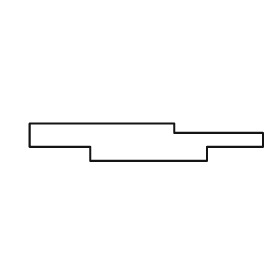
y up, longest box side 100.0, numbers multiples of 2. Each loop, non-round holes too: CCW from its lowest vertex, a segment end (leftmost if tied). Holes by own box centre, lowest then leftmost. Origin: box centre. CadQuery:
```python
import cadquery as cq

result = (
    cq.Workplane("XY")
    .moveTo(-24.0, -8.0)
    .lineTo(26.0, -8.0)
    .lineTo(26.0, -2.0)
    .lineTo(50.0, -2.0)
    .lineTo(50.0, 4.0)
    .lineTo(12.0, 4.0)
    .lineTo(12.0, 8.0)
    .lineTo(-50.0, 8.0)
    .lineTo(-50.0, -2.0)
    .lineTo(-24.0, -2.0)
    .close()
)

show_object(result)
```